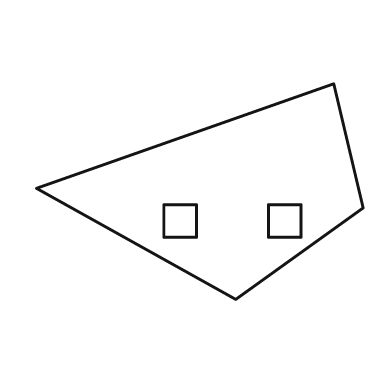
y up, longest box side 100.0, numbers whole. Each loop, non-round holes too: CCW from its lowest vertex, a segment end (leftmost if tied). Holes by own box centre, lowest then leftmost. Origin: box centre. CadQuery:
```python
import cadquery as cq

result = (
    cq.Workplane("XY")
    .moveTo(11.0, -33.0)
    .lineTo(50.0, -5.0)
    .lineTo(41.0, 33.0)
    .lineTo(-50.0, 1.0)
    .close()
    .moveTo(-11.0, -14.0)
    .lineTo(-1.0, -14.0)
    .lineTo(-1.0, -4.0)
    .lineTo(-11.0, -4.0)
    .close()
    .moveTo(21.0, -14.0)
    .lineTo(31.0, -14.0)
    .lineTo(31.0, -4.0)
    .lineTo(21.0, -4.0)
    .close()
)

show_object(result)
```